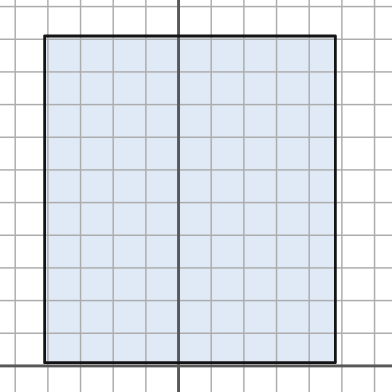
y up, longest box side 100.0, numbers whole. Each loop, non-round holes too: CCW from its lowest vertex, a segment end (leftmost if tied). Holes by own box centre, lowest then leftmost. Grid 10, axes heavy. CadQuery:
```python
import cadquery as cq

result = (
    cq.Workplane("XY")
    .moveTo(-41.0, 1.0)
    .lineTo(48.0, 1.0)
    .lineTo(48.0, 101.0)
    .lineTo(-41.0, 101.0)
    .close()
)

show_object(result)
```